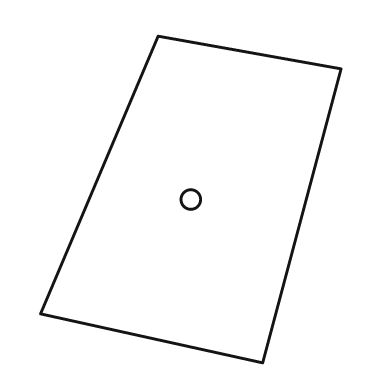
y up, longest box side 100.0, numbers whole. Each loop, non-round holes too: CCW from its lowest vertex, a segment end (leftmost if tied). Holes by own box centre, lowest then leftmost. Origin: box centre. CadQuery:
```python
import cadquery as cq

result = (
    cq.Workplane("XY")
    .moveTo(22.0, -50.0)
    .lineTo(46.0, 40.0)
    .lineTo(-10.0, 50.0)
    .lineTo(-46.0, -35.0)
    .close()
    .moveTo(0.0, 0.0)
    .circle(3.0)
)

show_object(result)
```